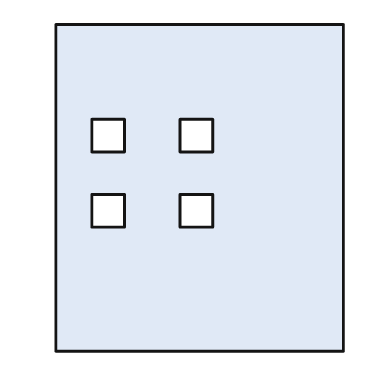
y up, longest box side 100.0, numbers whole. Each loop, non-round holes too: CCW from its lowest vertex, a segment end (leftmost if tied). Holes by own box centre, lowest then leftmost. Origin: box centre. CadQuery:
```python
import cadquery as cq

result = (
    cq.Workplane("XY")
    .moveTo(-44.0, -50.0)
    .lineTo(44.0, -50.0)
    .lineTo(44.0, 50.0)
    .lineTo(-44.0, 50.0)
    .close()
    .moveTo(-33.0, -12.0)
    .lineTo(-23.0, -12.0)
    .lineTo(-23.0, -2.0)
    .lineTo(-33.0, -2.0)
    .close()
    .moveTo(-6.0, -12.0)
    .lineTo(4.0, -12.0)
    .lineTo(4.0, -2.0)
    .lineTo(-6.0, -2.0)
    .close()
    .moveTo(-33.0, 11.0)
    .lineTo(-23.0, 11.0)
    .lineTo(-23.0, 21.0)
    .lineTo(-33.0, 21.0)
    .close()
    .moveTo(-6.0, 11.0)
    .lineTo(4.0, 11.0)
    .lineTo(4.0, 21.0)
    .lineTo(-6.0, 21.0)
    .close()
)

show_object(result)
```